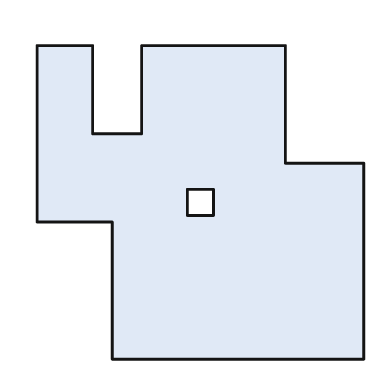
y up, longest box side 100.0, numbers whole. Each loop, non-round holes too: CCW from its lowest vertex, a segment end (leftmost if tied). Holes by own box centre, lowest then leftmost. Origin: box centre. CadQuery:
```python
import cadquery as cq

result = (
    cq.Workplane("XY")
    .moveTo(-27.0, -48.0)
    .lineTo(50.0, -48.0)
    .lineTo(50.0, 12.0)
    .lineTo(26.0, 12.0)
    .lineTo(26.0, 48.0)
    .lineTo(-18.0, 48.0)
    .lineTo(-18.0, 21.0)
    .lineTo(-33.0, 21.0)
    .lineTo(-33.0, 48.0)
    .lineTo(-50.0, 48.0)
    .lineTo(-50.0, -6.0)
    .lineTo(-27.0, -6.0)
    .close()
    .moveTo(-4.0, -4.0)
    .lineTo(4.0, -4.0)
    .lineTo(4.0, 4.0)
    .lineTo(-4.0, 4.0)
    .close()
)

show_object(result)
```